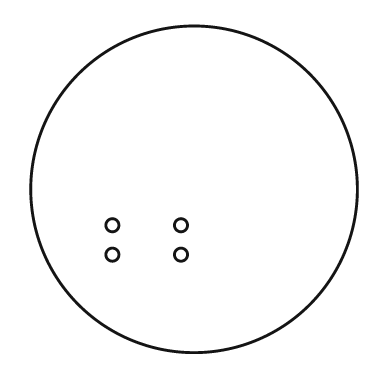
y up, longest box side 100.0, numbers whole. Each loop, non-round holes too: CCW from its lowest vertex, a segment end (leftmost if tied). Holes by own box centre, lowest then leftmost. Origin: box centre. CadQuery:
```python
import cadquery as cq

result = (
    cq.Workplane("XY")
    .moveTo(0.0, 0.0)
    .circle(50.0)
    .moveTo(-25.0, -20.0)
    .circle(2.0)
    .moveTo(-4.0, -20.0)
    .circle(2.0)
    .moveTo(-25.0, -11.0)
    .circle(2.0)
    .moveTo(-4.0, -11.0)
    .circle(2.0)
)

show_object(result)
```